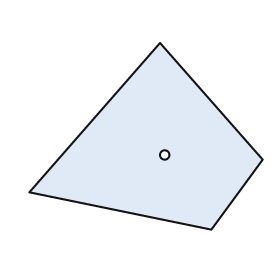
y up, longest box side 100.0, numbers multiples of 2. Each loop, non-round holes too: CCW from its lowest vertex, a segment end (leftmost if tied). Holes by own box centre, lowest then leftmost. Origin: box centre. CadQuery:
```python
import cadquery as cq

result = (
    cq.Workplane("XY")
    .moveTo(28.0, -40.0)
    .lineTo(50.0, -10.0)
    .lineTo(6.0, 40.0)
    .lineTo(-50.0, -24.0)
    .close()
    .moveTo(8.0, -8.0)
    .circle(2.0)
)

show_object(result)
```